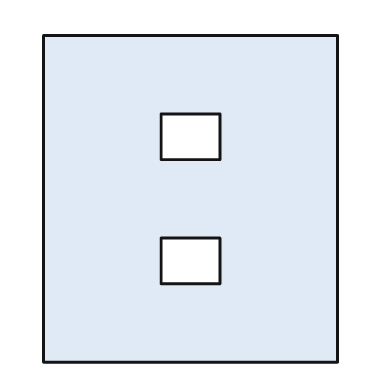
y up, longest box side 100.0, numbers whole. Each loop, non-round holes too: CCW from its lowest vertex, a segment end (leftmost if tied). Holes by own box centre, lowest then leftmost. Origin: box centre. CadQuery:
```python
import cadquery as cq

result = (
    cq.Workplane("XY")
    .moveTo(-45.0, -50.0)
    .lineTo(45.0, -50.0)
    .lineTo(45.0, 50.0)
    .lineTo(-45.0, 50.0)
    .close()
    .moveTo(-9.0, -26.0)
    .lineTo(9.0, -26.0)
    .lineTo(9.0, -12.0)
    .lineTo(-9.0, -12.0)
    .close()
    .moveTo(-9.0, 12.0)
    .lineTo(9.0, 12.0)
    .lineTo(9.0, 26.0)
    .lineTo(-9.0, 26.0)
    .close()
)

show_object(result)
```